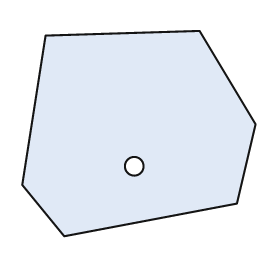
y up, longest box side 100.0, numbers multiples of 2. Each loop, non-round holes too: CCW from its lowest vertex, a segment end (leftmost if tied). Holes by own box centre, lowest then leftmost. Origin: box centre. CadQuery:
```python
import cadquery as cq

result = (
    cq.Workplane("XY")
    .moveTo(-32.0, -44.0)
    .lineTo(42.0, -30.0)
    .lineTo(50.0, 4.0)
    .lineTo(26.0, 44.0)
    .lineTo(-40.0, 42.0)
    .lineTo(-50.0, -22.0)
    .close()
    .moveTo(-2.0, -14.0)
    .circle(4.0)
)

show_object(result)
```